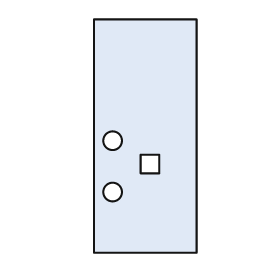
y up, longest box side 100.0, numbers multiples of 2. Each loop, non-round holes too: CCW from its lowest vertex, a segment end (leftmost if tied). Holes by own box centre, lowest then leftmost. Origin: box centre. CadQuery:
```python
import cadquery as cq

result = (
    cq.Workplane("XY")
    .moveTo(-22.0, -50.0)
    .lineTo(22.0, -50.0)
    .lineTo(22.0, 50.0)
    .lineTo(-22.0, 50.0)
    .close()
    .moveTo(-14.0, -24.0)
    .circle(4.0)
    .moveTo(-2.0, -16.0)
    .lineTo(6.0, -16.0)
    .lineTo(6.0, -8.0)
    .lineTo(-2.0, -8.0)
    .close()
    .moveTo(-14.0, -2.0)
    .circle(4.0)
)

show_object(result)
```